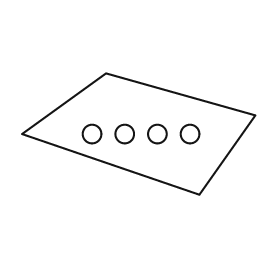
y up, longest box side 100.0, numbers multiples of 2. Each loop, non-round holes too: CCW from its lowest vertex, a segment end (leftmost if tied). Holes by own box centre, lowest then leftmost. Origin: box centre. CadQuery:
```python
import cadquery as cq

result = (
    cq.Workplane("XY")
    .moveTo(26.0, -26.0)
    .lineTo(50.0, 8.0)
    .lineTo(-14.0, 26.0)
    .lineTo(-50.0, 0.0)
    .close()
    .moveTo(-20.0, 0.0)
    .circle(4.0)
    .moveTo(-6.0, 0.0)
    .circle(4.0)
    .moveTo(8.0, 0.0)
    .circle(4.0)
    .moveTo(22.0, 0.0)
    .circle(4.0)
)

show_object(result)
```